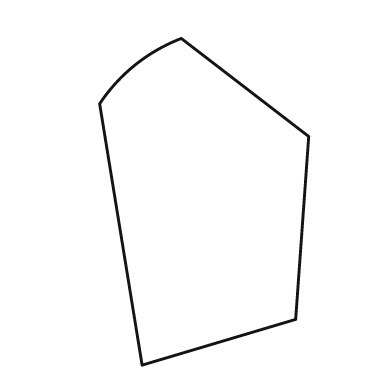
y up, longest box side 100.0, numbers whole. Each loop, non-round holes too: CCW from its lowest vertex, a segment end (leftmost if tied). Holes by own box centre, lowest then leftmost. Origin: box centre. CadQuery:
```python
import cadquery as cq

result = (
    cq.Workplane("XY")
    .moveTo(-19.0, -50.0)
    .lineTo(28.0, -36.0)
    .lineTo(32.0, 20.0)
    .lineTo(-7.0, 50.0)
    .threePointArc((-21.0, 42.0), (-32.0, 30.0))
    .close()
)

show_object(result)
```